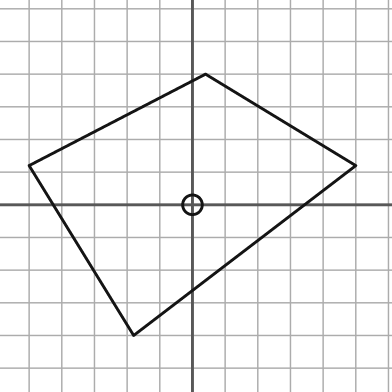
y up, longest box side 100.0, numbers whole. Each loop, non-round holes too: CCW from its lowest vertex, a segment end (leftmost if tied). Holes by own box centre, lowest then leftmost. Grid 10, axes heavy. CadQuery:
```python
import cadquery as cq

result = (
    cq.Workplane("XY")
    .moveTo(-18.0, -40.0)
    .lineTo(50.0, 12.0)
    .lineTo(4.0, 40.0)
    .lineTo(-50.0, 12.0)
    .close()
    .moveTo(0.0, 0.0)
    .circle(3.0)
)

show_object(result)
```